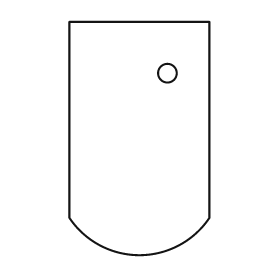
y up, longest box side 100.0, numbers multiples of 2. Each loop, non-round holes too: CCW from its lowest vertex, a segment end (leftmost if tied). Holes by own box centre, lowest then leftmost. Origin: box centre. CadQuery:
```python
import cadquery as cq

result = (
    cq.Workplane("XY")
    .moveTo(-30.0, -34.0)
    .threePointArc((0.0, -50.0), (30.0, -34.0))
    .lineTo(30.0, 50.0)
    .lineTo(-30.0, 50.0)
    .close()
    .moveTo(12.0, 28.0)
    .circle(4.0)
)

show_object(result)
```